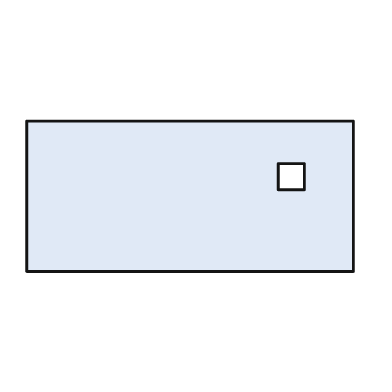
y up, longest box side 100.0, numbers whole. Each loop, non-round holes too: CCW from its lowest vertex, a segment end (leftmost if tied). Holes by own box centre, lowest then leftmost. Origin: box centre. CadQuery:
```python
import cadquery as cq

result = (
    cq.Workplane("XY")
    .moveTo(-50.0, -23.0)
    .lineTo(50.0, -23.0)
    .lineTo(50.0, 23.0)
    .lineTo(-50.0, 23.0)
    .close()
    .moveTo(27.0, 2.0)
    .lineTo(35.0, 2.0)
    .lineTo(35.0, 10.0)
    .lineTo(27.0, 10.0)
    .close()
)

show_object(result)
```